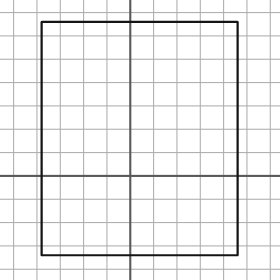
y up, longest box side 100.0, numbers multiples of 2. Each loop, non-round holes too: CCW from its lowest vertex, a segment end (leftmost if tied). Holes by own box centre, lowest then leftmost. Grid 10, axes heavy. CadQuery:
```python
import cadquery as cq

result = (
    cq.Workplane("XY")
    .moveTo(-38.0, -34.0)
    .lineTo(46.0, -34.0)
    .lineTo(46.0, 66.0)
    .lineTo(-38.0, 66.0)
    .close()
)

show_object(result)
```